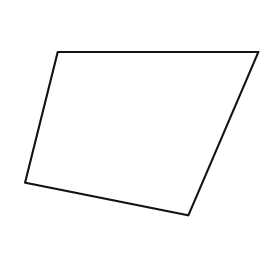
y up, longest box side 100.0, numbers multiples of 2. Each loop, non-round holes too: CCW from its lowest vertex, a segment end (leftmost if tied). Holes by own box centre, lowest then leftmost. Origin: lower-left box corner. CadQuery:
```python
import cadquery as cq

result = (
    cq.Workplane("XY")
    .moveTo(70.0, 0.0)
    .lineTo(100.0, 70.0)
    .lineTo(14.0, 70.0)
    .lineTo(0.0, 14.0)
    .close()
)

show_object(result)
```